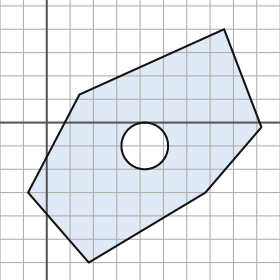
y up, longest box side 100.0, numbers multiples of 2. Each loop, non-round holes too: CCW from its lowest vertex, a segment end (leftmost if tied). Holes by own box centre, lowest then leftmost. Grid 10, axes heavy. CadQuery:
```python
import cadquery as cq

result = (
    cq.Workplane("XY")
    .moveTo(18.0, -60.0)
    .lineTo(68.0, -30.0)
    .lineTo(92.0, -2.0)
    .lineTo(76.0, 40.0)
    .lineTo(14.0, 12.0)
    .lineTo(-8.0, -30.0)
    .close()
    .moveTo(42.0, -10.0)
    .circle(10.0)
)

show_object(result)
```